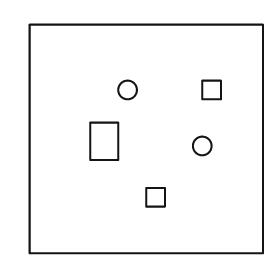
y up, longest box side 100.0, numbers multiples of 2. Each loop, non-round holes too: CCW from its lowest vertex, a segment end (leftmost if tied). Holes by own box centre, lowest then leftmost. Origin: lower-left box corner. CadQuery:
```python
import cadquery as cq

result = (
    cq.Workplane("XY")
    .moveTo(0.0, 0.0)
    .lineTo(100.0, 0.0)
    .lineTo(100.0, 98.0)
    .lineTo(0.0, 98.0)
    .close()
    .moveTo(50.0, 20.0)
    .lineTo(58.0, 20.0)
    .lineTo(58.0, 28.0)
    .lineTo(50.0, 28.0)
    .close()
    .moveTo(74.0, 46.0)
    .circle(4.0)
    .moveTo(26.0, 40.0)
    .lineTo(38.0, 40.0)
    .lineTo(38.0, 56.0)
    .lineTo(26.0, 56.0)
    .close()
    .moveTo(42.0, 70.0)
    .circle(4.0)
    .moveTo(74.0, 66.0)
    .lineTo(82.0, 66.0)
    .lineTo(82.0, 74.0)
    .lineTo(74.0, 74.0)
    .close()
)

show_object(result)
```